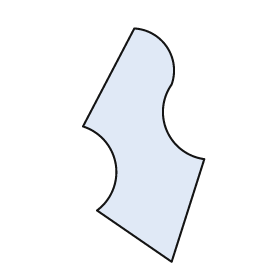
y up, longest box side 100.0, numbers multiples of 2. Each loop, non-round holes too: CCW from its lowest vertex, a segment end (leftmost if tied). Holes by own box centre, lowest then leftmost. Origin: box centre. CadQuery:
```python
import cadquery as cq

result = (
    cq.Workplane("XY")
    .moveTo(12.0, -50.0)
    .lineTo(26.0, -6.0)
    .threePointArc((10.0, 6.0), (12.0, 26.0))
    .threePointArc((10.0, 42.0), (-4.0, 50.0))
    .lineTo(-26.0, 8.0)
    .threePointArc((-12.0, -8.0), (-20.0, -28.0))
    .close()
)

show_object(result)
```